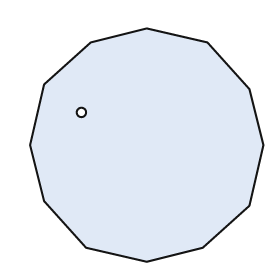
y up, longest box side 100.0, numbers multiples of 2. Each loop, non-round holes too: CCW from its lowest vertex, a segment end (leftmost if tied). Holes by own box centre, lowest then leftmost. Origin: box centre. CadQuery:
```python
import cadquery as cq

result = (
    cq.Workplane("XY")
    .moveTo(0.0, -50.0)
    .lineTo(24.0, -44.0)
    .lineTo(44.0, -26.0)
    .lineTo(50.0, 0.0)
    .lineTo(44.0, 24.0)
    .lineTo(26.0, 44.0)
    .lineTo(0.0, 50.0)
    .lineTo(-24.0, 44.0)
    .lineTo(-44.0, 26.0)
    .lineTo(-50.0, 0.0)
    .lineTo(-44.0, -24.0)
    .lineTo(-26.0, -44.0)
    .close()
    .moveTo(-28.0, 14.0)
    .circle(2.0)
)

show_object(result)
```